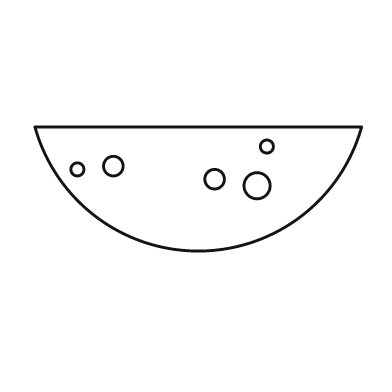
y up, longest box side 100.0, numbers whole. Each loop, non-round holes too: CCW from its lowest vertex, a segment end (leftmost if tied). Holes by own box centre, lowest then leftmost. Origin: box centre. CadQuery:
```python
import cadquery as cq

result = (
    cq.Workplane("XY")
    .moveTo(-50.0, 19.0)
    .threePointArc((0.0, -19.0), (50.0, 19.0))
    .close()
    .moveTo(18.0, 1.0)
    .circle(4.0)
    .moveTo(5.0, 3.0)
    .circle(3.0)
    .moveTo(-37.0, 6.0)
    .circle(2.0)
    .moveTo(-26.0, 7.0)
    .circle(3.0)
    .moveTo(21.0, 13.0)
    .circle(2.0)
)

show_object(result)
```